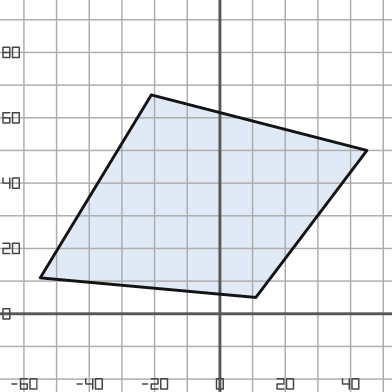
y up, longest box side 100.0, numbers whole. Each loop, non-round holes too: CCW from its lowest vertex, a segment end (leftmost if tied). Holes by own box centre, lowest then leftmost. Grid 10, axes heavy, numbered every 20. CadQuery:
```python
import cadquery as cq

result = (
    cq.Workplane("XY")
    .moveTo(11.0, 5.0)
    .lineTo(45.0, 50.0)
    .lineTo(-21.0, 67.0)
    .lineTo(-55.0, 11.0)
    .close()
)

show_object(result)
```